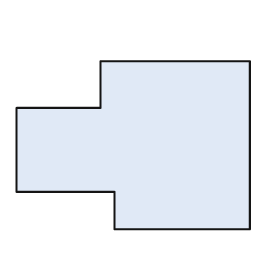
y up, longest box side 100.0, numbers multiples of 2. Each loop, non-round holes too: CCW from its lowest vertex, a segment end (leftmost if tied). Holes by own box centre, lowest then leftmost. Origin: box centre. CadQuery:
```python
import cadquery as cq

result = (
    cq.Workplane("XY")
    .moveTo(-8.0, -36.0)
    .lineTo(50.0, -36.0)
    .lineTo(50.0, 36.0)
    .lineTo(-14.0, 36.0)
    .lineTo(-14.0, 16.0)
    .lineTo(-50.0, 16.0)
    .lineTo(-50.0, -20.0)
    .lineTo(-8.0, -20.0)
    .close()
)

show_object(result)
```